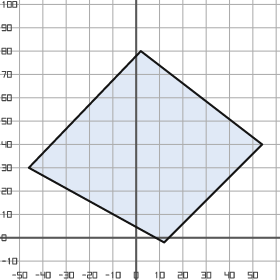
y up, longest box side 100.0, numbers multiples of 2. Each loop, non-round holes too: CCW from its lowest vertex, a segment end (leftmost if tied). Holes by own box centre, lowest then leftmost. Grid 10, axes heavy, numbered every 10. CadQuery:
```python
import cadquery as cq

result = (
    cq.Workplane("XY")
    .moveTo(12.0, -2.0)
    .lineTo(54.0, 40.0)
    .lineTo(2.0, 80.0)
    .lineTo(-46.0, 30.0)
    .close()
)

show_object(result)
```